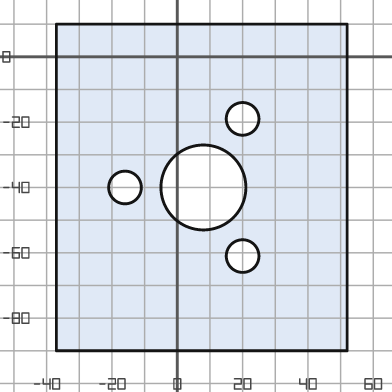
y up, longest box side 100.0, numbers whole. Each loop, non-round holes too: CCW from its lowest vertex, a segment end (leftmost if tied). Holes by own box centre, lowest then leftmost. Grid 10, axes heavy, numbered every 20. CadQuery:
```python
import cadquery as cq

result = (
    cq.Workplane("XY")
    .moveTo(-37.0, -90.0)
    .lineTo(52.0, -90.0)
    .lineTo(52.0, 10.0)
    .lineTo(-37.0, 10.0)
    .close()
    .moveTo(20.0, -61.0)
    .circle(5.0)
    .moveTo(-16.0, -40.0)
    .circle(5.0)
    .moveTo(8.0, -40.0)
    .circle(13.0)
    .moveTo(20.0, -19.0)
    .circle(5.0)
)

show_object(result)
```